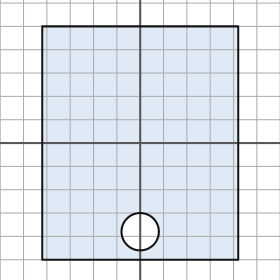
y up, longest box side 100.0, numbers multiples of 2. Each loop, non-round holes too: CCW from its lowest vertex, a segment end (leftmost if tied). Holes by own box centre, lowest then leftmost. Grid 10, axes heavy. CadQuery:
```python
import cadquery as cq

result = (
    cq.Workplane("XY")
    .moveTo(-42.0, -50.0)
    .lineTo(42.0, -50.0)
    .lineTo(42.0, 50.0)
    .lineTo(-42.0, 50.0)
    .close()
    .moveTo(0.0, -38.0)
    .circle(8.0)
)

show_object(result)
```